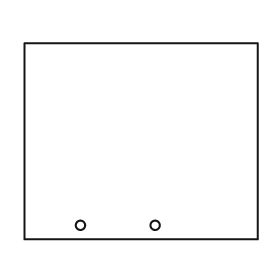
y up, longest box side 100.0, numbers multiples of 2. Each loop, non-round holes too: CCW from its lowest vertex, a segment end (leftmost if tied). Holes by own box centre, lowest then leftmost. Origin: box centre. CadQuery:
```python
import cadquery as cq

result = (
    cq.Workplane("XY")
    .moveTo(-50.0, -42.0)
    .lineTo(50.0, -42.0)
    .lineTo(50.0, 42.0)
    .lineTo(-50.0, 42.0)
    .close()
    .moveTo(-26.0, -36.0)
    .circle(2.0)
    .moveTo(6.0, -36.0)
    .circle(2.0)
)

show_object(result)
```